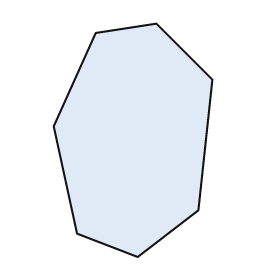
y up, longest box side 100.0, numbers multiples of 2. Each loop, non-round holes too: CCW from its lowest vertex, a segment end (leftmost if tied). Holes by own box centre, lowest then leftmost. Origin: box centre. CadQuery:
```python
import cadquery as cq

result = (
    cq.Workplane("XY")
    .moveTo(2.0, -50.0)
    .lineTo(28.0, -30.0)
    .lineTo(34.0, 26.0)
    .lineTo(10.0, 50.0)
    .lineTo(-16.0, 46.0)
    .lineTo(-34.0, 6.0)
    .lineTo(-24.0, -40.0)
    .close()
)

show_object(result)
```